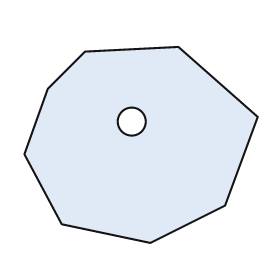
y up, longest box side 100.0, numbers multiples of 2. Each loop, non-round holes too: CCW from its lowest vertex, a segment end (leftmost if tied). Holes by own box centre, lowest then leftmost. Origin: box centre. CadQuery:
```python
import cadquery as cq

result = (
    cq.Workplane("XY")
    .moveTo(4.0, -42.0)
    .lineTo(36.0, -26.0)
    .lineTo(50.0, 12.0)
    .lineTo(16.0, 42.0)
    .lineTo(-24.0, 40.0)
    .lineTo(-40.0, 24.0)
    .lineTo(-50.0, -4.0)
    .lineTo(-34.0, -34.0)
    .close()
    .moveTo(-4.0, 10.0)
    .circle(6.0)
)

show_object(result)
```